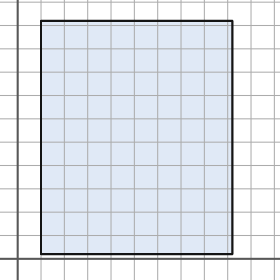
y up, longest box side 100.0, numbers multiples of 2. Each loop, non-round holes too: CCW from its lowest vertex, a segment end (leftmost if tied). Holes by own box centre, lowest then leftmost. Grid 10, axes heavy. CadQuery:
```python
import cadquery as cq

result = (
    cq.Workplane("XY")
    .moveTo(10.0, 2.0)
    .lineTo(92.0, 2.0)
    .lineTo(92.0, 102.0)
    .lineTo(10.0, 102.0)
    .close()
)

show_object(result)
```